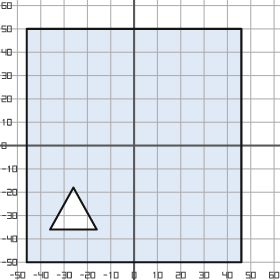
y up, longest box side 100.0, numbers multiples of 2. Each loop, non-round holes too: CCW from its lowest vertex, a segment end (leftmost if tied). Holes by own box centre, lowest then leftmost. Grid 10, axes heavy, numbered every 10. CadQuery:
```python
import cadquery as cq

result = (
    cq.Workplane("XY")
    .moveTo(-46.0, -50.0)
    .lineTo(46.0, -50.0)
    .lineTo(46.0, 50.0)
    .lineTo(-46.0, 50.0)
    .close()
    .moveTo(-36.0, -36.0)
    .lineTo(-16.0, -36.0)
    .lineTo(-26.0, -18.0)
    .close()
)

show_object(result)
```